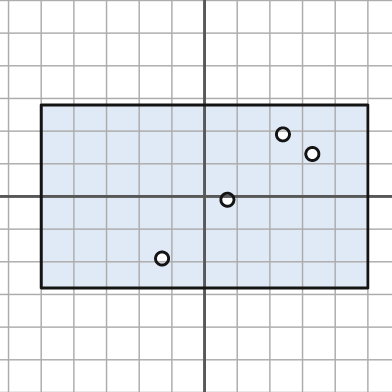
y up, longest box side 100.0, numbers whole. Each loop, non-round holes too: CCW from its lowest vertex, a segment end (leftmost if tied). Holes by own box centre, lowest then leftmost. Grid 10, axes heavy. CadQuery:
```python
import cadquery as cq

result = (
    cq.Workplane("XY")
    .moveTo(-50.0, -28.0)
    .lineTo(50.0, -28.0)
    .lineTo(50.0, 28.0)
    .lineTo(-50.0, 28.0)
    .close()
    .moveTo(-13.0, -19.0)
    .circle(2.0)
    .moveTo(7.0, -1.0)
    .circle(2.0)
    .moveTo(33.0, 13.0)
    .circle(2.0)
    .moveTo(24.0, 19.0)
    .circle(2.0)
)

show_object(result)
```